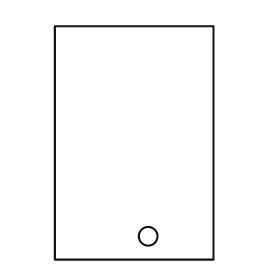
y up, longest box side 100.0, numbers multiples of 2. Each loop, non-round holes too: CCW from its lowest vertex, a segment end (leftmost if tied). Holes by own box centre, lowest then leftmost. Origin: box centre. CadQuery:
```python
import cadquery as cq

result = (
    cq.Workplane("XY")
    .moveTo(-34.0, -50.0)
    .lineTo(34.0, -50.0)
    .lineTo(34.0, 50.0)
    .lineTo(-34.0, 50.0)
    .close()
    .moveTo(6.0, -40.0)
    .circle(4.0)
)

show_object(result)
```